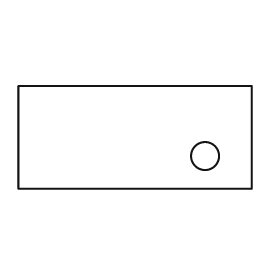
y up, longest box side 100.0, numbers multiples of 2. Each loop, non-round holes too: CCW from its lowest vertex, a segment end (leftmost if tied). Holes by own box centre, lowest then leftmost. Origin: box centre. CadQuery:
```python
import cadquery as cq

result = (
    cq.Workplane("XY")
    .moveTo(-50.0, -22.0)
    .lineTo(50.0, -22.0)
    .lineTo(50.0, 22.0)
    .lineTo(-50.0, 22.0)
    .close()
    .moveTo(30.0, -8.0)
    .circle(6.0)
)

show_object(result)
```